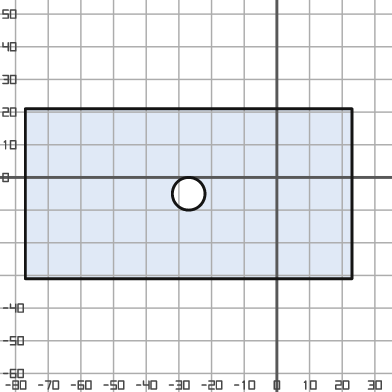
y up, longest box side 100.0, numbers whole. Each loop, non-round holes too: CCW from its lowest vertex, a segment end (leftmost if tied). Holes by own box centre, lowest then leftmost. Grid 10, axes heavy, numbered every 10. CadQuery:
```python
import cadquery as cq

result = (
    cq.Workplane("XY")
    .moveTo(-77.0, -31.0)
    .lineTo(23.0, -31.0)
    .lineTo(23.0, 21.0)
    .lineTo(-77.0, 21.0)
    .close()
    .moveTo(-27.0, -5.0)
    .circle(5.0)
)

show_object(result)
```